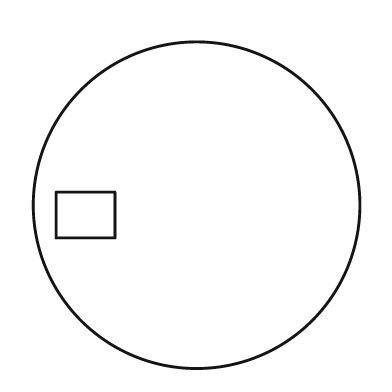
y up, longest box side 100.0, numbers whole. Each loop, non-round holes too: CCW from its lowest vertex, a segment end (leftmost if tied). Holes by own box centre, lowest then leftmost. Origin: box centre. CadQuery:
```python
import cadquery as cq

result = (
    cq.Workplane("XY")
    .moveTo(0.0, 0.0)
    .circle(50.0)
    .moveTo(-43.0, -10.0)
    .lineTo(-25.0, -10.0)
    .lineTo(-25.0, 4.0)
    .lineTo(-43.0, 4.0)
    .close()
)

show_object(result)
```